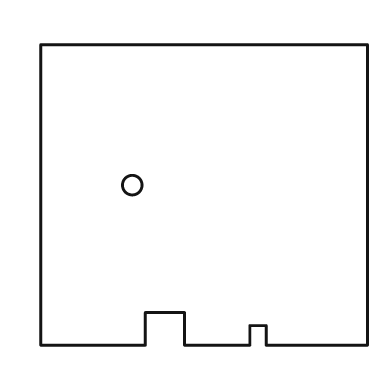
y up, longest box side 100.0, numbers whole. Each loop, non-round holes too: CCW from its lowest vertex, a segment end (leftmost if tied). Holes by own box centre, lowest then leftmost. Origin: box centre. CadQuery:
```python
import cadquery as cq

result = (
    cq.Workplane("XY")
    .moveTo(-50.0, -46.0)
    .lineTo(-18.0, -46.0)
    .lineTo(-18.0, -36.0)
    .lineTo(-6.0, -36.0)
    .lineTo(-6.0, -46.0)
    .lineTo(14.0, -46.0)
    .lineTo(14.0, -40.0)
    .lineTo(19.0, -40.0)
    .lineTo(19.0, -46.0)
    .lineTo(50.0, -46.0)
    .lineTo(50.0, 46.0)
    .lineTo(-50.0, 46.0)
    .close()
    .moveTo(-22.0, 3.0)
    .circle(3.0)
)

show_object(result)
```